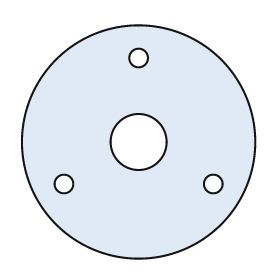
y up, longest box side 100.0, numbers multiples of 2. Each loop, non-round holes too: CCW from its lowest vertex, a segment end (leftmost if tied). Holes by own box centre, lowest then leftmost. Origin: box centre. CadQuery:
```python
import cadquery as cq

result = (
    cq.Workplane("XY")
    .moveTo(0.0, 0.0)
    .circle(50.0)
    .moveTo(-32.0, -18.0)
    .circle(4.0)
    .moveTo(32.0, -18.0)
    .circle(4.0)
    .moveTo(0.0, 0.0)
    .circle(12.0)
    .moveTo(0.0, 36.0)
    .circle(4.0)
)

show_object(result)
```